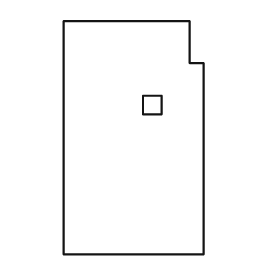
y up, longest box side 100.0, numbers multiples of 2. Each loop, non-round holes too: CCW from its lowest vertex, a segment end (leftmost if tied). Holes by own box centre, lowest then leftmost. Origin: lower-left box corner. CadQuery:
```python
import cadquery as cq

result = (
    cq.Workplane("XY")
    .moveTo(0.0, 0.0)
    .lineTo(60.0, 0.0)
    .lineTo(60.0, 82.0)
    .lineTo(54.0, 82.0)
    .lineTo(54.0, 100.0)
    .lineTo(0.0, 100.0)
    .close()
    .moveTo(34.0, 60.0)
    .lineTo(42.0, 60.0)
    .lineTo(42.0, 68.0)
    .lineTo(34.0, 68.0)
    .close()
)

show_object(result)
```